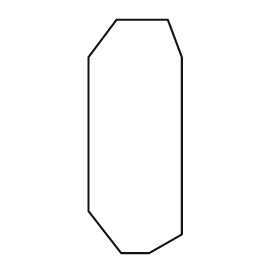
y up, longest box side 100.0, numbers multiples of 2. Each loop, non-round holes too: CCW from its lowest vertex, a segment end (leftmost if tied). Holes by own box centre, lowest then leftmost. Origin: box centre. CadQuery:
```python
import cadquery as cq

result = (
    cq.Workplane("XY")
    .moveTo(-6.0, -50.0)
    .lineTo(6.0, -50.0)
    .lineTo(20.0, -42.0)
    .lineTo(20.0, 34.0)
    .lineTo(14.0, 50.0)
    .lineTo(-8.0, 50.0)
    .lineTo(-20.0, 34.0)
    .lineTo(-20.0, -32.0)
    .close()
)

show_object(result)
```